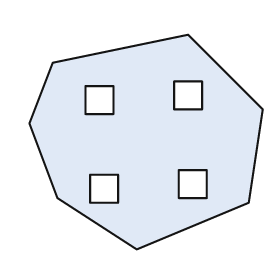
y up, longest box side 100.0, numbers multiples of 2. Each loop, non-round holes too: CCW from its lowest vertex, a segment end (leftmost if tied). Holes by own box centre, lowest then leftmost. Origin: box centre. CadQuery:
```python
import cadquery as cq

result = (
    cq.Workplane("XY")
    .moveTo(-4.0, -46.0)
    .lineTo(44.0, -26.0)
    .lineTo(50.0, 14.0)
    .lineTo(18.0, 46.0)
    .lineTo(-40.0, 34.0)
    .lineTo(-50.0, 8.0)
    .lineTo(-38.0, -24.0)
    .close()
    .moveTo(-24.0, -26.0)
    .lineTo(-12.0, -26.0)
    .lineTo(-12.0, -14.0)
    .lineTo(-24.0, -14.0)
    .close()
    .moveTo(14.0, -24.0)
    .lineTo(26.0, -24.0)
    .lineTo(26.0, -12.0)
    .lineTo(14.0, -12.0)
    .close()
    .moveTo(-26.0, 12.0)
    .lineTo(-14.0, 12.0)
    .lineTo(-14.0, 24.0)
    .lineTo(-26.0, 24.0)
    .close()
    .moveTo(12.0, 14.0)
    .lineTo(24.0, 14.0)
    .lineTo(24.0, 26.0)
    .lineTo(12.0, 26.0)
    .close()
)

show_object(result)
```